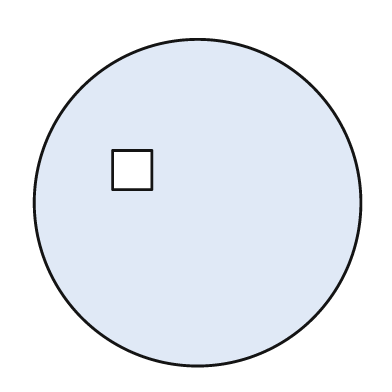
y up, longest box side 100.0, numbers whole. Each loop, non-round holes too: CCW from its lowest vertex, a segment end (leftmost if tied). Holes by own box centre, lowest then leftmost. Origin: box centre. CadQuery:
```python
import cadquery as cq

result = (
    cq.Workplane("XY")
    .moveTo(0.0, 0.0)
    .circle(50.0)
    .moveTo(-26.0, 4.0)
    .lineTo(-14.0, 4.0)
    .lineTo(-14.0, 16.0)
    .lineTo(-26.0, 16.0)
    .close()
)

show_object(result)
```